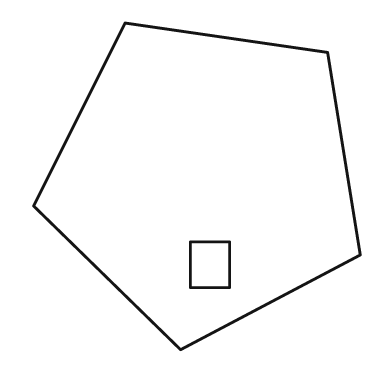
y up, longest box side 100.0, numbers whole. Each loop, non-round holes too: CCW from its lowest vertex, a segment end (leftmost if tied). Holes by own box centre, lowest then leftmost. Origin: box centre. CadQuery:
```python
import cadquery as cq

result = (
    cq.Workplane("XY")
    .moveTo(-5.0, -50.0)
    .lineTo(50.0, -21.0)
    .lineTo(40.0, 41.0)
    .lineTo(-22.0, 50.0)
    .lineTo(-50.0, -6.0)
    .close()
    .moveTo(-2.0, -31.0)
    .lineTo(10.0, -31.0)
    .lineTo(10.0, -17.0)
    .lineTo(-2.0, -17.0)
    .close()
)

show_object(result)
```